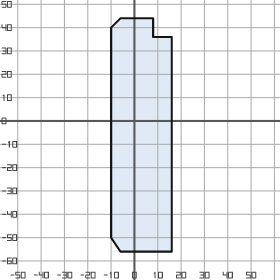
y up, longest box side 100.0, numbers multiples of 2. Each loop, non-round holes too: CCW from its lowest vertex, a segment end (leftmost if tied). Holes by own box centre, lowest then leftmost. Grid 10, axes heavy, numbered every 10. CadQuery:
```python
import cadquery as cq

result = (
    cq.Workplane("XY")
    .moveTo(-6.0, -56.0)
    .lineTo(16.0, -56.0)
    .lineTo(16.0, 36.0)
    .lineTo(8.0, 36.0)
    .lineTo(8.0, 44.0)
    .lineTo(-6.0, 44.0)
    .lineTo(-10.0, 40.0)
    .lineTo(-10.0, -50.0)
    .close()
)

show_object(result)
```